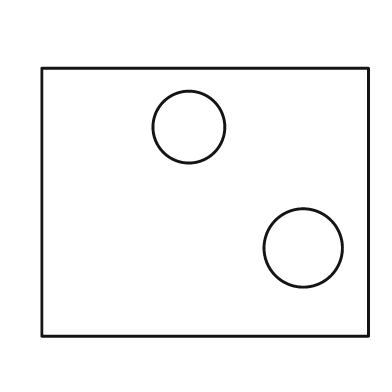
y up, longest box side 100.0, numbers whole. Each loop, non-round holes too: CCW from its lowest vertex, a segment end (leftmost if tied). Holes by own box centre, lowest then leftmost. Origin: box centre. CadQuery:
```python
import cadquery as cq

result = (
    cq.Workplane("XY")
    .moveTo(-50.0, -41.0)
    .lineTo(50.0, -41.0)
    .lineTo(50.0, 41.0)
    .lineTo(-50.0, 41.0)
    .close()
    .moveTo(30.0, -14.0)
    .circle(12.0)
    .moveTo(-5.0, 23.0)
    .circle(11.0)
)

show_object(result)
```